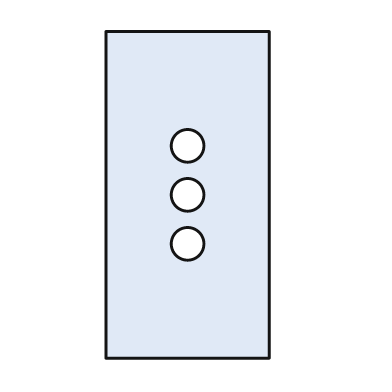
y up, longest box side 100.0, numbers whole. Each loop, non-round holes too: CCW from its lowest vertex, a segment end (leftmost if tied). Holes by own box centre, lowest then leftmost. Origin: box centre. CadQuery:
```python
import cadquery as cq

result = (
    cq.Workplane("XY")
    .moveTo(-25.0, -50.0)
    .lineTo(25.0, -50.0)
    .lineTo(25.0, 50.0)
    .lineTo(-25.0, 50.0)
    .close()
    .moveTo(0.0, -15.0)
    .circle(5.0)
    .moveTo(0.0, 0.0)
    .circle(5.0)
    .moveTo(0.0, 15.0)
    .circle(5.0)
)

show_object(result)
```